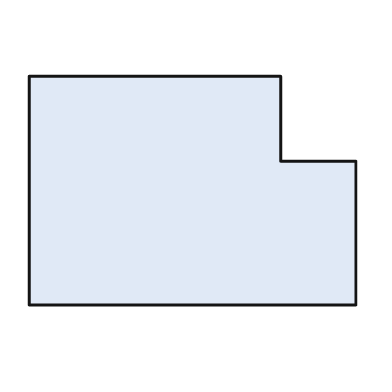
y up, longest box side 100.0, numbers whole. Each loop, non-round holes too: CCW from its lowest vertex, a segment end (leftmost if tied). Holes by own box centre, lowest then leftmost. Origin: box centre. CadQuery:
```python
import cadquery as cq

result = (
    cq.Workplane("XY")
    .moveTo(-50.0, -35.0)
    .lineTo(50.0, -35.0)
    .lineTo(50.0, 9.0)
    .lineTo(27.0, 9.0)
    .lineTo(27.0, 35.0)
    .lineTo(-50.0, 35.0)
    .close()
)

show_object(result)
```